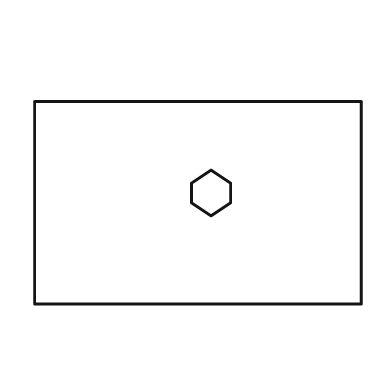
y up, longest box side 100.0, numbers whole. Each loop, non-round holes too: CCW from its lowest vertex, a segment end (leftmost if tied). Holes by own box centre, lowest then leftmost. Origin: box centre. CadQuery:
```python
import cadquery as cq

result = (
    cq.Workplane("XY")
    .moveTo(-50.0, -31.0)
    .lineTo(50.0, -31.0)
    .lineTo(50.0, 31.0)
    .lineTo(-50.0, 31.0)
    .close()
    .moveTo(4.0, -4.0)
    .lineTo(10.0, 0.0)
    .lineTo(10.0, 6.0)
    .lineTo(4.0, 10.0)
    .lineTo(-2.0, 6.0)
    .lineTo(-2.0, 0.0)
    .close()
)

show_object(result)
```